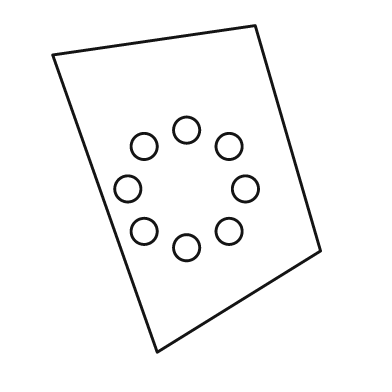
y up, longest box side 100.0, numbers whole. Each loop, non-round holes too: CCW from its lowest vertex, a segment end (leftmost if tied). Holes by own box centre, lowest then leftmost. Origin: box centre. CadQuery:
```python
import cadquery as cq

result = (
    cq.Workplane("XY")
    .moveTo(-9.0, -50.0)
    .lineTo(41.0, -19.0)
    .lineTo(21.0, 50.0)
    .lineTo(-41.0, 41.0)
    .close()
    .moveTo(0.0, -18.0)
    .circle(4.0)
    .moveTo(-13.0, -13.0)
    .circle(4.0)
    .moveTo(13.0, -13.0)
    .circle(4.0)
    .moveTo(-18.0, 0.0)
    .circle(4.0)
    .moveTo(18.0, 0.0)
    .circle(4.0)
    .moveTo(-13.0, 13.0)
    .circle(4.0)
    .moveTo(13.0, 13.0)
    .circle(4.0)
    .moveTo(0.0, 18.0)
    .circle(4.0)
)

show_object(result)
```